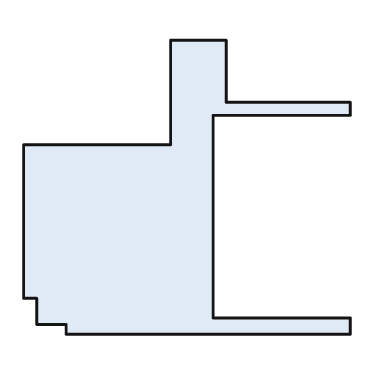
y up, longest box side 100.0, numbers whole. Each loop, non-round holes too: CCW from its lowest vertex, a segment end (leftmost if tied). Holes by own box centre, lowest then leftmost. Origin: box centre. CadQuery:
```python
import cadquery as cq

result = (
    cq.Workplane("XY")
    .moveTo(-37.0, -45.0)
    .lineTo(50.0, -45.0)
    .lineTo(50.0, -40.0)
    .lineTo(8.0, -40.0)
    .lineTo(8.0, 22.0)
    .lineTo(50.0, 22.0)
    .lineTo(50.0, 26.0)
    .lineTo(12.0, 26.0)
    .lineTo(12.0, 45.0)
    .lineTo(-5.0, 45.0)
    .lineTo(-5.0, 13.0)
    .lineTo(-50.0, 13.0)
    .lineTo(-50.0, -34.0)
    .lineTo(-46.0, -34.0)
    .lineTo(-46.0, -42.0)
    .lineTo(-37.0, -42.0)
    .close()
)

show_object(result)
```